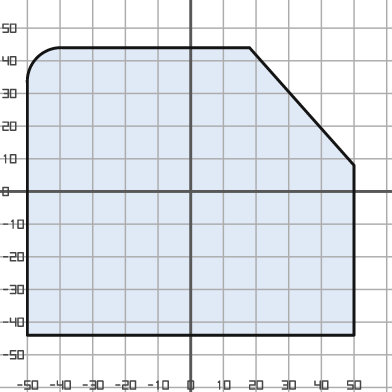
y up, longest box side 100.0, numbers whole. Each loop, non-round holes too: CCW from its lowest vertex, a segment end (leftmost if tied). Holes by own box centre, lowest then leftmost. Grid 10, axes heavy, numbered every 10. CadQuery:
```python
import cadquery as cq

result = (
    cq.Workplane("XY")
    .moveTo(-50.0, -44.0)
    .lineTo(50.0, -44.0)
    .lineTo(50.0, 8.0)
    .lineTo(18.0, 44.0)
    .lineTo(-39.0, 44.0)
    .threePointArc((-47.0, 41.0), (-50.0, 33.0))
    .close()
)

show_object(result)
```